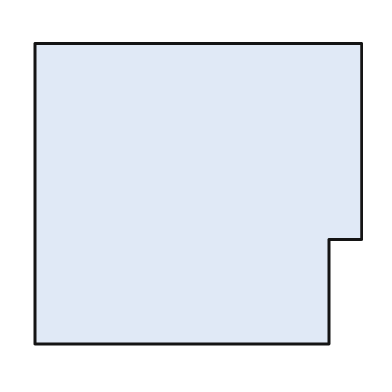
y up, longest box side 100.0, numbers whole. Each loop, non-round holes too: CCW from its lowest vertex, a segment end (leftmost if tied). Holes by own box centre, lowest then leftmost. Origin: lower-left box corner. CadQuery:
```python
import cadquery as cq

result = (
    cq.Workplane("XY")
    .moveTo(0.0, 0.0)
    .lineTo(90.0, 0.0)
    .lineTo(90.0, 32.0)
    .lineTo(100.0, 32.0)
    .lineTo(100.0, 92.0)
    .lineTo(0.0, 92.0)
    .close()
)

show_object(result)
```